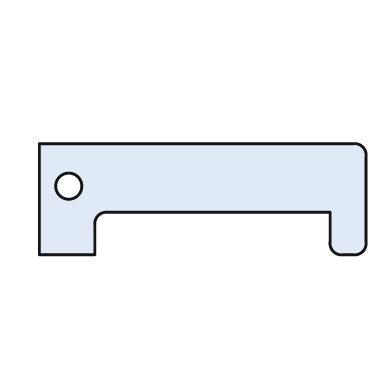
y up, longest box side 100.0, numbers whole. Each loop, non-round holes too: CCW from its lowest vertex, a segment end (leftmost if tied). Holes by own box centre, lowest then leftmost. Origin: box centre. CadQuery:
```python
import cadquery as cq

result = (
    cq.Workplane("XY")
    .moveTo(-50.0, -17.0)
    .lineTo(-33.0, -17.0)
    .lineTo(-33.0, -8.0)
    .threePointArc((-32.0, -5.0), (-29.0, -4.0))
    .lineTo(39.0, -4.0)
    .lineTo(39.0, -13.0)
    .threePointArc((40.0, -16.0), (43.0, -17.0))
    .lineTo(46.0, -17.0)
    .threePointArc((49.0, -16.0), (50.0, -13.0))
    .lineTo(50.0, 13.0)
    .threePointArc((49.0, 16.0), (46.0, 17.0))
    .lineTo(-50.0, 17.0)
    .close()
    .moveTo(-41.0, 4.0)
    .circle(4.0)
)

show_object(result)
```